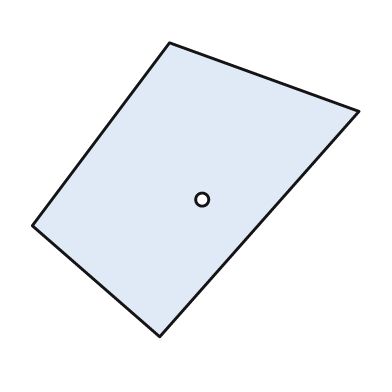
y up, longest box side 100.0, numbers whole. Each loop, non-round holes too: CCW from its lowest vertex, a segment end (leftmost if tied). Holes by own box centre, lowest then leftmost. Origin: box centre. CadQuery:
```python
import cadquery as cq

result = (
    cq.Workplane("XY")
    .moveTo(-11.0, -45.0)
    .lineTo(50.0, 24.0)
    .lineTo(-8.0, 45.0)
    .lineTo(-50.0, -11.0)
    .close()
    .moveTo(2.0, -3.0)
    .circle(2.0)
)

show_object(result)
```